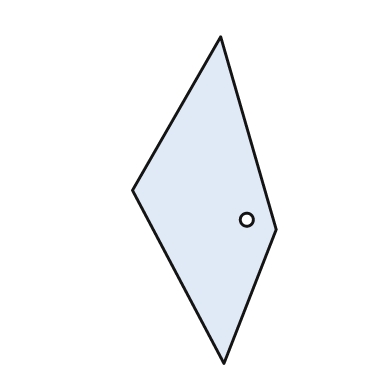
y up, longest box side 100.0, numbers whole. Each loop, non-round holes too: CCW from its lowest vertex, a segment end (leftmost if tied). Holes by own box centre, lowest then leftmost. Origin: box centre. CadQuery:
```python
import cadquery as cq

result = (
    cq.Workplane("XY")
    .moveTo(6.0, -50.0)
    .lineTo(22.0, -9.0)
    .lineTo(5.0, 50.0)
    .lineTo(-22.0, 3.0)
    .close()
    .moveTo(13.0, -6.0)
    .circle(2.0)
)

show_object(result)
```